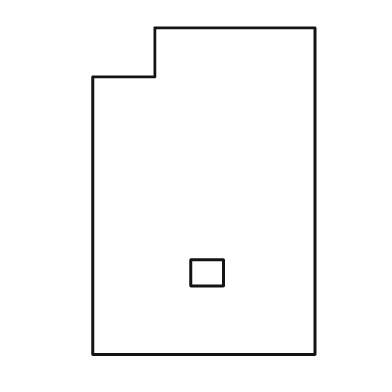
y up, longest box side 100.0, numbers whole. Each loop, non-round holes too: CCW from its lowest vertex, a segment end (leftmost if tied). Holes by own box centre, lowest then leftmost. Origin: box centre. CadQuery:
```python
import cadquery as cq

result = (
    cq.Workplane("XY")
    .moveTo(-34.0, -50.0)
    .lineTo(34.0, -50.0)
    .lineTo(34.0, 50.0)
    .lineTo(-15.0, 50.0)
    .lineTo(-15.0, 35.0)
    .lineTo(-34.0, 35.0)
    .close()
    .moveTo(-4.0, -29.0)
    .lineTo(6.0, -29.0)
    .lineTo(6.0, -21.0)
    .lineTo(-4.0, -21.0)
    .close()
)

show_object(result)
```